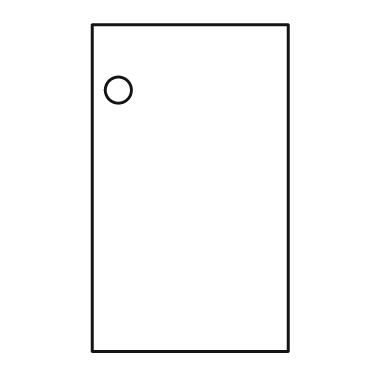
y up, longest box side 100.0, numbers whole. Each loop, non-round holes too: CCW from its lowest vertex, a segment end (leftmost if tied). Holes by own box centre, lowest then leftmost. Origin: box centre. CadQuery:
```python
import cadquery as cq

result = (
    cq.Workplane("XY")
    .moveTo(-30.0, -50.0)
    .lineTo(30.0, -50.0)
    .lineTo(30.0, 50.0)
    .lineTo(-30.0, 50.0)
    .close()
    .moveTo(-22.0, 30.0)
    .circle(4.0)
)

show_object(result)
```